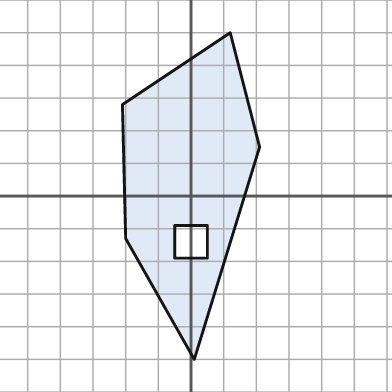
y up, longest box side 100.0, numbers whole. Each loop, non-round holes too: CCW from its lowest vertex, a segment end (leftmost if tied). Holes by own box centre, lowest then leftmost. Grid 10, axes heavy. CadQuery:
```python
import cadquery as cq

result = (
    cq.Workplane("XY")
    .moveTo(1.0, -50.0)
    .lineTo(21.0, 15.0)
    .lineTo(12.0, 50.0)
    .lineTo(-21.0, 28.0)
    .lineTo(-20.0, -13.0)
    .close()
    .moveTo(-5.0, -19.0)
    .lineTo(5.0, -19.0)
    .lineTo(5.0, -9.0)
    .lineTo(-5.0, -9.0)
    .close()
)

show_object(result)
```